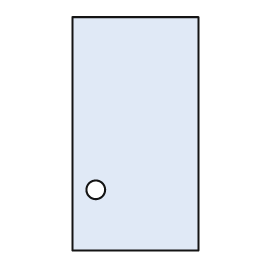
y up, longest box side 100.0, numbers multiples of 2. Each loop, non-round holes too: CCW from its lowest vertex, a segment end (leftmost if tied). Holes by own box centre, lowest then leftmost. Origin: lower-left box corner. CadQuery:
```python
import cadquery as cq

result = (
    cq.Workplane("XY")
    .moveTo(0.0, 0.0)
    .lineTo(54.0, 0.0)
    .lineTo(54.0, 100.0)
    .lineTo(0.0, 100.0)
    .close()
    .moveTo(10.0, 26.0)
    .circle(4.0)
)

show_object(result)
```